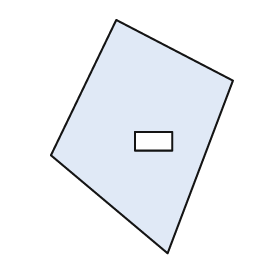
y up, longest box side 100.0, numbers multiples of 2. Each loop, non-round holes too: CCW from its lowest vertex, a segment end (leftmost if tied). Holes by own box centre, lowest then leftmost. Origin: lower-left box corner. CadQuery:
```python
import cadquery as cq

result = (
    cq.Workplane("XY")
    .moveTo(50.0, 0.0)
    .lineTo(78.0, 74.0)
    .lineTo(28.0, 100.0)
    .lineTo(0.0, 42.0)
    .close()
    .moveTo(36.0, 44.0)
    .lineTo(52.0, 44.0)
    .lineTo(52.0, 52.0)
    .lineTo(36.0, 52.0)
    .close()
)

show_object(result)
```